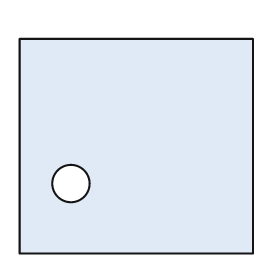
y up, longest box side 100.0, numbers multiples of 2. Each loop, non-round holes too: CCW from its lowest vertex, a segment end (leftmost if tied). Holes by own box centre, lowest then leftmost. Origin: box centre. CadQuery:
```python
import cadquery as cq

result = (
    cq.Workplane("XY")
    .moveTo(-50.0, -46.0)
    .lineTo(50.0, -46.0)
    .lineTo(50.0, 46.0)
    .lineTo(-50.0, 46.0)
    .close()
    .moveTo(-28.0, -16.0)
    .circle(8.0)
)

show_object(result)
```